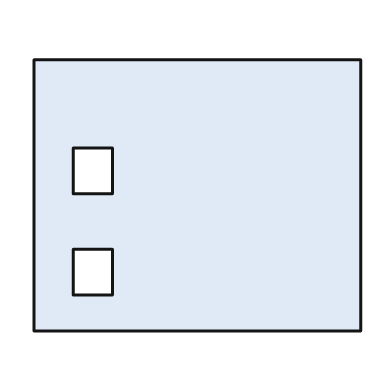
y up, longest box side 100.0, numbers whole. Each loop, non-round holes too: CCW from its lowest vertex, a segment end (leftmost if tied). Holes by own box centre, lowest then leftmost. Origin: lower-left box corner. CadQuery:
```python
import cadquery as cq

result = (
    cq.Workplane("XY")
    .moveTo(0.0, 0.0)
    .lineTo(100.0, 0.0)
    .lineTo(100.0, 83.0)
    .lineTo(0.0, 83.0)
    .close()
    .moveTo(12.0, 11.0)
    .lineTo(24.0, 11.0)
    .lineTo(24.0, 25.0)
    .lineTo(12.0, 25.0)
    .close()
    .moveTo(12.0, 42.0)
    .lineTo(24.0, 42.0)
    .lineTo(24.0, 56.0)
    .lineTo(12.0, 56.0)
    .close()
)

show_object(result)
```